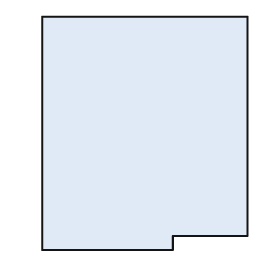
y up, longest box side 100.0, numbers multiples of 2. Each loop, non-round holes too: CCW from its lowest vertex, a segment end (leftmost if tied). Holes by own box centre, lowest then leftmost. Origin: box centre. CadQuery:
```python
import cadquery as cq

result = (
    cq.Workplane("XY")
    .moveTo(-44.0, -50.0)
    .lineTo(12.0, -50.0)
    .lineTo(12.0, -44.0)
    .lineTo(44.0, -44.0)
    .lineTo(44.0, 50.0)
    .lineTo(-44.0, 50.0)
    .close()
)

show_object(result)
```